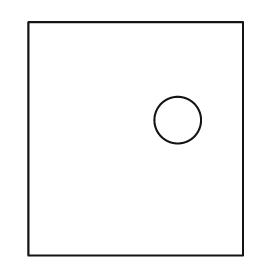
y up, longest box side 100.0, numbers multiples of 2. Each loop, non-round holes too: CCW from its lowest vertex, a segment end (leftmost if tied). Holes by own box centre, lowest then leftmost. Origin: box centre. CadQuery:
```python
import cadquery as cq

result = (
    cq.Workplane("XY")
    .moveTo(-46.0, -50.0)
    .lineTo(46.0, -50.0)
    .lineTo(46.0, 50.0)
    .lineTo(-46.0, 50.0)
    .close()
    .moveTo(18.0, 8.0)
    .circle(10.0)
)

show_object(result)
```